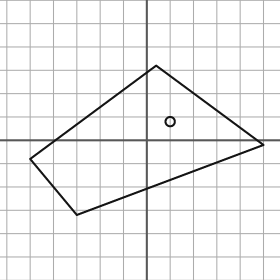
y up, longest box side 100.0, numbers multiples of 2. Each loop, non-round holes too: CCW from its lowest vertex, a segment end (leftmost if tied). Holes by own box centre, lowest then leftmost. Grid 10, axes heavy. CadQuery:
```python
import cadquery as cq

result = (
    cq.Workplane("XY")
    .moveTo(-30.0, -32.0)
    .lineTo(50.0, -2.0)
    .lineTo(4.0, 32.0)
    .lineTo(-50.0, -8.0)
    .close()
    .moveTo(10.0, 8.0)
    .circle(2.0)
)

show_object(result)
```